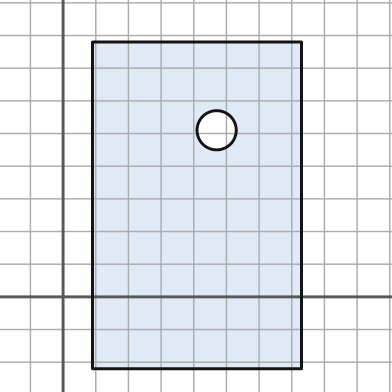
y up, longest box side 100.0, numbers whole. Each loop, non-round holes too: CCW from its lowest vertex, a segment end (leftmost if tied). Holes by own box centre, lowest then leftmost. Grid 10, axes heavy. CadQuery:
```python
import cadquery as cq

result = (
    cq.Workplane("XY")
    .moveTo(9.0, -22.0)
    .lineTo(73.0, -22.0)
    .lineTo(73.0, 78.0)
    .lineTo(9.0, 78.0)
    .close()
    .moveTo(47.0, 51.0)
    .circle(6.0)
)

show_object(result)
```